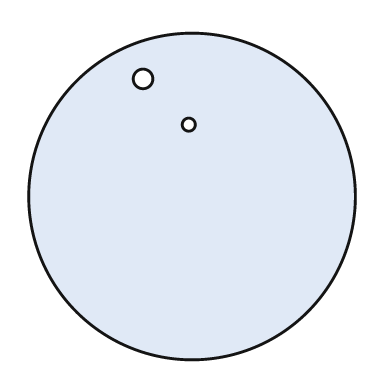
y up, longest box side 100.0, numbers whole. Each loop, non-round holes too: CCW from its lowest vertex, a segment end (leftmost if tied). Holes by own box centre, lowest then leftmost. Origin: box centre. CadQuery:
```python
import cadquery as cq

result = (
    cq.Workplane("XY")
    .moveTo(0.0, 0.0)
    .circle(50.0)
    .moveTo(-1.0, 22.0)
    .circle(2.0)
    .moveTo(-15.0, 36.0)
    .circle(3.0)
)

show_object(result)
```